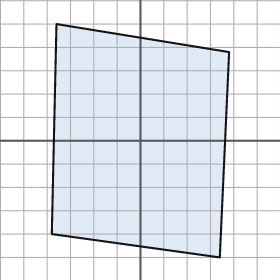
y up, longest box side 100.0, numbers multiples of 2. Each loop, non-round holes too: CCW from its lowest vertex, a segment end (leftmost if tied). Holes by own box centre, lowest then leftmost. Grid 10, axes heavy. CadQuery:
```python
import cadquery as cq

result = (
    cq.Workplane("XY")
    .moveTo(34.0, -50.0)
    .lineTo(38.0, 38.0)
    .lineTo(-36.0, 50.0)
    .lineTo(-38.0, -40.0)
    .close()
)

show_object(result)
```